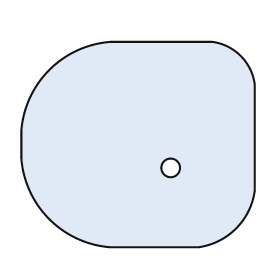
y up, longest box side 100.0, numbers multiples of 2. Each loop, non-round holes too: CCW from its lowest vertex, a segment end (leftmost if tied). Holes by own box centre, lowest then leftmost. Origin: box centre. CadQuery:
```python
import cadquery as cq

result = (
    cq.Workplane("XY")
    .moveTo(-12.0, -44.0)
    .lineTo(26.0, -44.0)
    .threePointArc((42.0, -36.0), (50.0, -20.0))
    .lineTo(50.0, 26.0)
    .threePointArc((44.0, 38.0), (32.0, 44.0))
    .lineTo(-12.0, 44.0)
    .threePointArc((-38.0, 32.0), (-50.0, 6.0))
    .lineTo(-50.0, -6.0)
    .threePointArc((-38.0, -32.0), (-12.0, -44.0))
    .close()
    .moveTo(14.0, -10.0)
    .circle(4.0)
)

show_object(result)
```